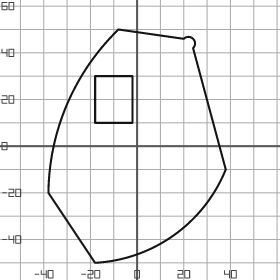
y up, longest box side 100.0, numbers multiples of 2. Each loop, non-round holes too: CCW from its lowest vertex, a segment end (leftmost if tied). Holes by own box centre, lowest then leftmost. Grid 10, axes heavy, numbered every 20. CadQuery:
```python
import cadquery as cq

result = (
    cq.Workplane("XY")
    .moveTo(-18.0, -50.0)
    .threePointArc((16.0, -38.0), (38.0, -10.0))
    .lineTo(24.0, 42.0)
    .threePointArc((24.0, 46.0), (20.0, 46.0))
    .lineTo(-8.0, 50.0)
    .threePointArc((-30.0, 18.0), (-38.0, -20.0))
    .close()
    .moveTo(-18.0, 10.0)
    .lineTo(-2.0, 10.0)
    .lineTo(-2.0, 30.0)
    .lineTo(-18.0, 30.0)
    .close()
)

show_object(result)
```